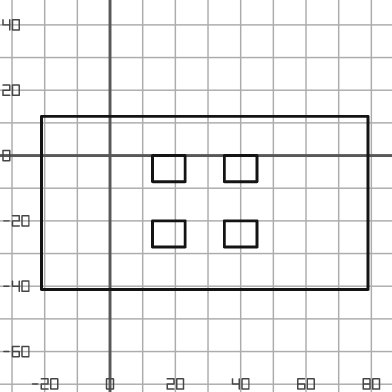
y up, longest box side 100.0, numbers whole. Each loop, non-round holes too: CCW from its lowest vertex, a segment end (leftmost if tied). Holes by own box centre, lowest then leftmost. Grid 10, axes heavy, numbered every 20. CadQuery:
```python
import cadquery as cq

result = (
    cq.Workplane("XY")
    .moveTo(-21.0, -41.0)
    .lineTo(79.0, -41.0)
    .lineTo(79.0, 12.0)
    .lineTo(-21.0, 12.0)
    .close()
    .moveTo(13.0, -28.0)
    .lineTo(23.0, -28.0)
    .lineTo(23.0, -20.0)
    .lineTo(13.0, -20.0)
    .close()
    .moveTo(35.0, -28.0)
    .lineTo(45.0, -28.0)
    .lineTo(45.0, -20.0)
    .lineTo(35.0, -20.0)
    .close()
    .moveTo(13.0, -8.0)
    .lineTo(23.0, -8.0)
    .lineTo(23.0, 0.0)
    .lineTo(13.0, 0.0)
    .close()
    .moveTo(35.0, -8.0)
    .lineTo(45.0, -8.0)
    .lineTo(45.0, 0.0)
    .lineTo(35.0, 0.0)
    .close()
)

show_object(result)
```